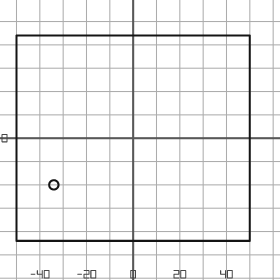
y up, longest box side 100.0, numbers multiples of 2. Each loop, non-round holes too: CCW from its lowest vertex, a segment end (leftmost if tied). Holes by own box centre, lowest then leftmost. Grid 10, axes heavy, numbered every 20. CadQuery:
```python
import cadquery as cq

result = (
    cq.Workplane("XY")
    .moveTo(-50.0, -44.0)
    .lineTo(50.0, -44.0)
    .lineTo(50.0, 44.0)
    .lineTo(-50.0, 44.0)
    .close()
    .moveTo(-34.0, -20.0)
    .circle(2.0)
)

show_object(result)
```